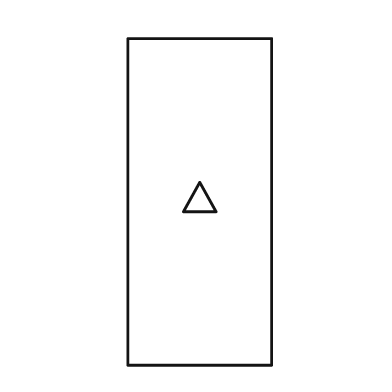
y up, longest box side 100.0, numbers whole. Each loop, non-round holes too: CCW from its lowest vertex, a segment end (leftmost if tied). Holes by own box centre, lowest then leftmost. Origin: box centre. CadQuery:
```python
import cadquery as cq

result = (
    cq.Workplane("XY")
    .moveTo(-22.0, -50.0)
    .lineTo(22.0, -50.0)
    .lineTo(22.0, 50.0)
    .lineTo(-22.0, 50.0)
    .close()
    .moveTo(-5.0, -3.0)
    .lineTo(5.0, -3.0)
    .lineTo(0.0, 6.0)
    .close()
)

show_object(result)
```